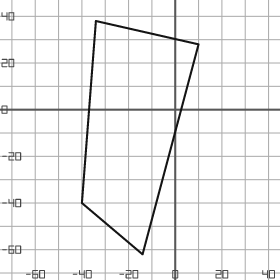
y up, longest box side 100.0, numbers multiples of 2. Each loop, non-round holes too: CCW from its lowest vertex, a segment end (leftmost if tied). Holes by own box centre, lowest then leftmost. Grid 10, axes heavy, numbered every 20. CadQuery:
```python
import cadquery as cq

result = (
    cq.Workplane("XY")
    .moveTo(-14.0, -62.0)
    .lineTo(10.0, 28.0)
    .lineTo(-34.0, 38.0)
    .lineTo(-40.0, -40.0)
    .close()
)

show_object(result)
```